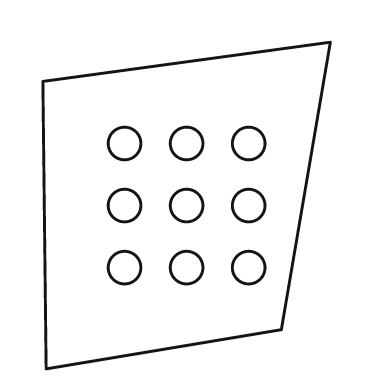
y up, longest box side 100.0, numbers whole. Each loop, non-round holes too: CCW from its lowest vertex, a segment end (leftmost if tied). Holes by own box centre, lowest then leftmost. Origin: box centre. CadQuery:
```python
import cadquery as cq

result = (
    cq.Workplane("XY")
    .moveTo(-43.0, -50.0)
    .lineTo(29.0, -38.0)
    .lineTo(44.0, 50.0)
    .lineTo(-44.0, 38.0)
    .close()
    .moveTo(-19.0, -19.0)
    .circle(5.0)
    .moveTo(0.0, -19.0)
    .circle(5.0)
    .moveTo(19.0, -19.0)
    .circle(5.0)
    .moveTo(-19.0, 0.0)
    .circle(5.0)
    .moveTo(0.0, 0.0)
    .circle(5.0)
    .moveTo(19.0, 0.0)
    .circle(5.0)
    .moveTo(-19.0, 19.0)
    .circle(5.0)
    .moveTo(0.0, 19.0)
    .circle(5.0)
    .moveTo(19.0, 19.0)
    .circle(5.0)
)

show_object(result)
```